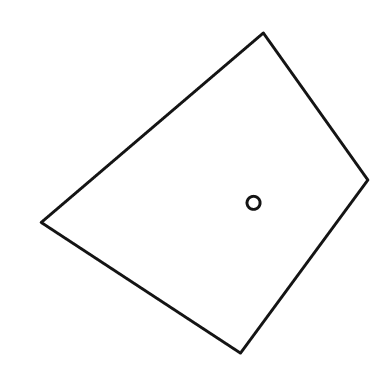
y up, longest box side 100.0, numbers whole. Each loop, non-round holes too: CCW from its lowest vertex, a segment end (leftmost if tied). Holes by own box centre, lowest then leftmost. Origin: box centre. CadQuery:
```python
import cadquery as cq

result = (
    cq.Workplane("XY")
    .moveTo(11.0, -49.0)
    .lineTo(50.0, 4.0)
    .lineTo(18.0, 49.0)
    .lineTo(-50.0, -9.0)
    .close()
    .moveTo(15.0, -3.0)
    .circle(2.0)
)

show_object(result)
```